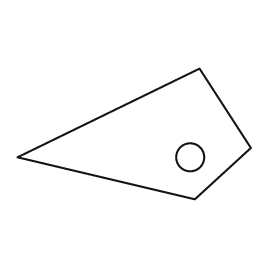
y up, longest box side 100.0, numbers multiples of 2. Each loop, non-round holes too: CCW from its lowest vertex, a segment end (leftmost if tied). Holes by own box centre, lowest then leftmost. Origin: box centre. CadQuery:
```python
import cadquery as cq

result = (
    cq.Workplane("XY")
    .moveTo(26.0, -28.0)
    .lineTo(50.0, -6.0)
    .lineTo(28.0, 28.0)
    .lineTo(-50.0, -10.0)
    .close()
    .moveTo(24.0, -10.0)
    .circle(6.0)
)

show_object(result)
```